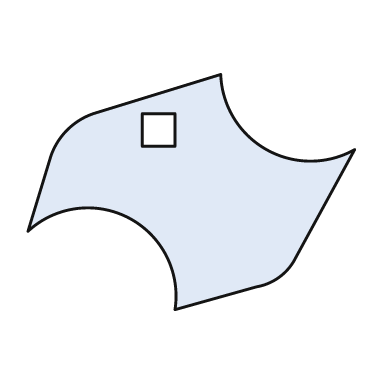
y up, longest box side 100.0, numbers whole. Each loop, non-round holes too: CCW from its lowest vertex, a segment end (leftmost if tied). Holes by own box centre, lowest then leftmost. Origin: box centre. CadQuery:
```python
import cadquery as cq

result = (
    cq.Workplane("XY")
    .moveTo(-5.0, -36.0)
    .lineTo(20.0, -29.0)
    .threePointArc((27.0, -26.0), (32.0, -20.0))
    .lineTo(50.0, 13.0)
    .threePointArc((23.0, 13.0), (9.0, 36.0))
    .lineTo(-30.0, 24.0)
    .threePointArc((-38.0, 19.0), (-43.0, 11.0))
    .lineTo(-50.0, -12.0)
    .threePointArc((-19.0, -8.0), (-5.0, -36.0))
    .close()
    .moveTo(-15.0, 14.0)
    .lineTo(-5.0, 14.0)
    .lineTo(-5.0, 24.0)
    .lineTo(-15.0, 24.0)
    .close()
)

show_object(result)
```